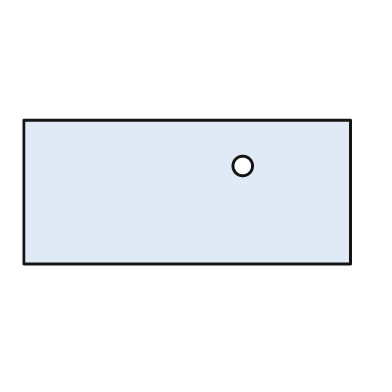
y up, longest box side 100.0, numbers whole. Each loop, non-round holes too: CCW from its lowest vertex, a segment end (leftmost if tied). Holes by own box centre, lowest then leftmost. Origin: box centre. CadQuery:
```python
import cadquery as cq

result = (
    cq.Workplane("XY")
    .moveTo(-50.0, -22.0)
    .lineTo(50.0, -22.0)
    .lineTo(50.0, 22.0)
    .lineTo(-50.0, 22.0)
    .close()
    .moveTo(17.0, 8.0)
    .circle(3.0)
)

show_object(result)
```